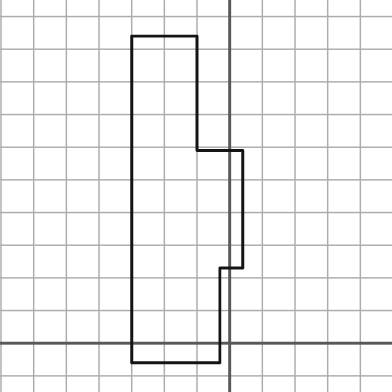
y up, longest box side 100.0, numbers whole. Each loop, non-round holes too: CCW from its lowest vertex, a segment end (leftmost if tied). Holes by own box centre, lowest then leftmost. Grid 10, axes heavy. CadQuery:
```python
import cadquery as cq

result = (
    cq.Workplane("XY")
    .moveTo(-30.0, -6.0)
    .lineTo(-3.0, -6.0)
    .lineTo(-3.0, 23.0)
    .lineTo(4.0, 23.0)
    .lineTo(4.0, 59.0)
    .lineTo(-10.0, 59.0)
    .lineTo(-10.0, 94.0)
    .lineTo(-30.0, 94.0)
    .close()
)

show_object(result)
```